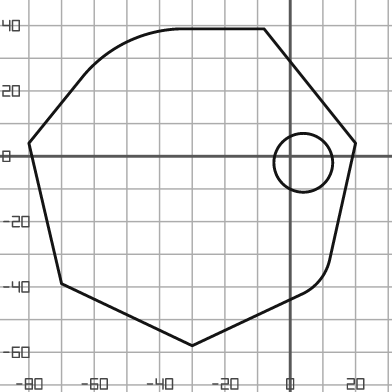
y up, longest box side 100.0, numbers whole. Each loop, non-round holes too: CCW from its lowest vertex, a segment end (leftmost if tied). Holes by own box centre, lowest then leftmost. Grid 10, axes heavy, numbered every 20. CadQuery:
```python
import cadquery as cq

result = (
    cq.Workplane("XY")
    .moveTo(-30.0, -58.0)
    .lineTo(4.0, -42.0)
    .threePointArc((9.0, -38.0), (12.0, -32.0))
    .lineTo(20.0, 4.0)
    .lineTo(-8.0, 39.0)
    .lineTo(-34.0, 39.0)
    .threePointArc((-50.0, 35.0), (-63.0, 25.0))
    .lineTo(-80.0, 4.0)
    .lineTo(-70.0, -39.0)
    .close()
    .moveTo(4.0, -2.0)
    .circle(9.0)
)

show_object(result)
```